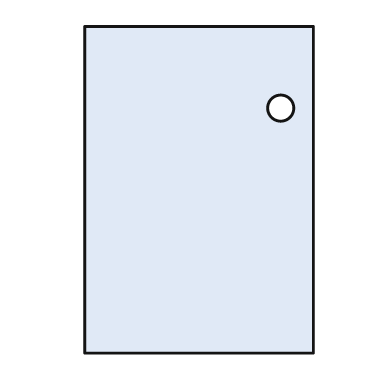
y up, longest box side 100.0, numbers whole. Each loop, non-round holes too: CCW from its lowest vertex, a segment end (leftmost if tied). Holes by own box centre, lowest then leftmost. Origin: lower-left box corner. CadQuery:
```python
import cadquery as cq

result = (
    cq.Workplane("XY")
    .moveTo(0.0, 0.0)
    .lineTo(70.0, 0.0)
    .lineTo(70.0, 100.0)
    .lineTo(0.0, 100.0)
    .close()
    .moveTo(60.0, 75.0)
    .circle(4.0)
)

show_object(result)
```